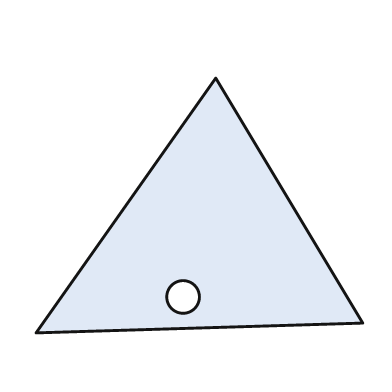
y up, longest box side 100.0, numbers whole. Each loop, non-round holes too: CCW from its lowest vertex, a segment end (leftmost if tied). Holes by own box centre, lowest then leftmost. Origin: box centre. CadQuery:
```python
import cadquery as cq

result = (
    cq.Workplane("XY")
    .moveTo(-50.0, -39.0)
    .lineTo(50.0, -36.0)
    .lineTo(5.0, 39.0)
    .close()
    .moveTo(-5.0, -28.0)
    .circle(5.0)
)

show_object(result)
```